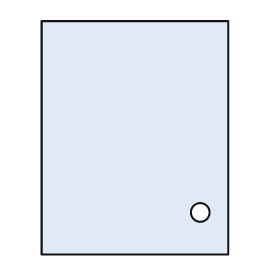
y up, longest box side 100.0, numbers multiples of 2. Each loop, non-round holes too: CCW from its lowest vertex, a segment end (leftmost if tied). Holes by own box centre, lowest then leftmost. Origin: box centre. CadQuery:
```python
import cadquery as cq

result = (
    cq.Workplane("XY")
    .moveTo(-40.0, -50.0)
    .lineTo(40.0, -50.0)
    .lineTo(40.0, 50.0)
    .lineTo(-40.0, 50.0)
    .close()
    .moveTo(28.0, -32.0)
    .circle(4.0)
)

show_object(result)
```